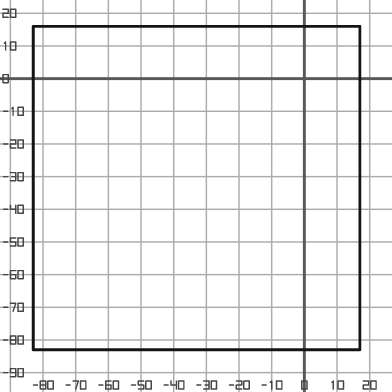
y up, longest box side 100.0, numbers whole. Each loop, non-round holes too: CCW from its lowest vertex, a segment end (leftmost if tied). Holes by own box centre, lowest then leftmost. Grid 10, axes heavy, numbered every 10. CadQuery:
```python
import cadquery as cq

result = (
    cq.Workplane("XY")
    .moveTo(-83.0, -83.0)
    .lineTo(17.0, -83.0)
    .lineTo(17.0, 16.0)
    .lineTo(-83.0, 16.0)
    .close()
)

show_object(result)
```